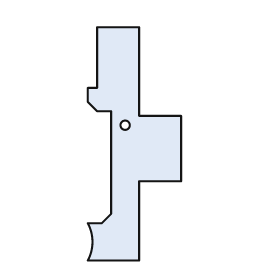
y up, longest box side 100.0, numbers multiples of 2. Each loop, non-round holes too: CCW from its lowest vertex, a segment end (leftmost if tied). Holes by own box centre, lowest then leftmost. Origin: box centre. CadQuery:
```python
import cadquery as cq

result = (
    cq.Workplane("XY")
    .moveTo(-20.0, -50.0)
    .lineTo(2.0, -50.0)
    .lineTo(2.0, -16.0)
    .lineTo(20.0, -16.0)
    .lineTo(20.0, 12.0)
    .lineTo(2.0, 12.0)
    .lineTo(2.0, 50.0)
    .lineTo(-16.0, 50.0)
    .lineTo(-16.0, 24.0)
    .lineTo(-20.0, 24.0)
    .lineTo(-20.0, 18.0)
    .lineTo(-16.0, 14.0)
    .lineTo(-10.0, 14.0)
    .lineTo(-10.0, -30.0)
    .lineTo(-14.0, -34.0)
    .lineTo(-20.0, -34.0)
    .threePointArc((-18.0, -42.0), (-20.0, -50.0))
    .close()
    .moveTo(-4.0, 8.0)
    .circle(2.0)
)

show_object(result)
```